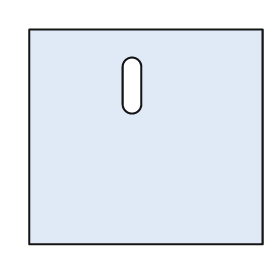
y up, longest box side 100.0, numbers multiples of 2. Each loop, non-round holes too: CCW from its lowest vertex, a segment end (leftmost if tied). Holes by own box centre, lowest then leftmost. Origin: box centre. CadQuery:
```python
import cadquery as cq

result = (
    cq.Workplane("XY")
    .moveTo(-50.0, -46.0)
    .lineTo(50.0, -46.0)
    .lineTo(50.0, 46.0)
    .lineTo(-50.0, 46.0)
    .close()
    .moveTo(-10.0, 14.0)
    .threePointArc((-6.0, 10.0), (-2.0, 14.0))
    .lineTo(-2.0, 30.0)
    .threePointArc((-6.0, 34.0), (-10.0, 30.0))
    .close()
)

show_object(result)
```